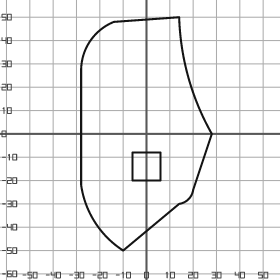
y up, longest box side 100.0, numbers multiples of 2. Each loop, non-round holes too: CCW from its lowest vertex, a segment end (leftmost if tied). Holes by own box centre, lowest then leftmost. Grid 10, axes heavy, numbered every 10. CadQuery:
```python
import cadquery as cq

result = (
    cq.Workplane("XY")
    .moveTo(-10.0, -50.0)
    .lineTo(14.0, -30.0)
    .threePointArc((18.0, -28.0), (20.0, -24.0))
    .lineTo(28.0, 0.0)
    .threePointArc((18.0, 24.0), (14.0, 50.0))
    .lineTo(-14.0, 48.0)
    .threePointArc((-24.0, 40.0), (-28.0, 28.0))
    .lineTo(-28.0, -22.0)
    .threePointArc((-22.0, -38.0), (-10.0, -50.0))
    .close()
    .moveTo(-6.0, -20.0)
    .lineTo(6.0, -20.0)
    .lineTo(6.0, -8.0)
    .lineTo(-6.0, -8.0)
    .close()
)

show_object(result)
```